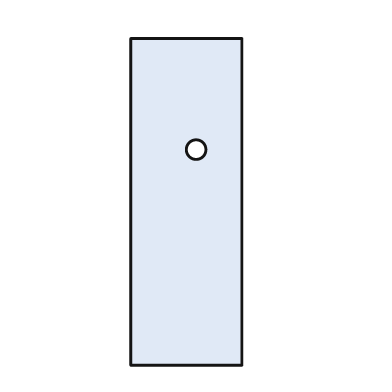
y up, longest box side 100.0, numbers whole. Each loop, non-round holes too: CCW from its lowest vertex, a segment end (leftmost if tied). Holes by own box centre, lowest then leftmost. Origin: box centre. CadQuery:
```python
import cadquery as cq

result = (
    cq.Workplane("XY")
    .moveTo(-17.0, -50.0)
    .lineTo(17.0, -50.0)
    .lineTo(17.0, 50.0)
    .lineTo(-17.0, 50.0)
    .close()
    .moveTo(3.0, 16.0)
    .circle(3.0)
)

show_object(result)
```